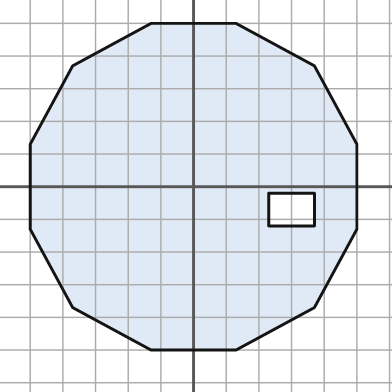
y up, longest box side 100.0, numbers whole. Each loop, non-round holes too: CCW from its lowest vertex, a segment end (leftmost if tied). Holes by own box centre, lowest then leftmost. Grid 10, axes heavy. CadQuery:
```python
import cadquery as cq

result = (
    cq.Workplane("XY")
    .moveTo(-13.0, -50.0)
    .lineTo(13.0, -50.0)
    .lineTo(37.0, -37.0)
    .lineTo(50.0, -13.0)
    .lineTo(50.0, 13.0)
    .lineTo(37.0, 37.0)
    .lineTo(13.0, 50.0)
    .lineTo(-13.0, 50.0)
    .lineTo(-37.0, 37.0)
    .lineTo(-50.0, 13.0)
    .lineTo(-50.0, -13.0)
    .lineTo(-37.0, -37.0)
    .close()
    .moveTo(23.0, -12.0)
    .lineTo(37.0, -12.0)
    .lineTo(37.0, -2.0)
    .lineTo(23.0, -2.0)
    .close()
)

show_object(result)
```